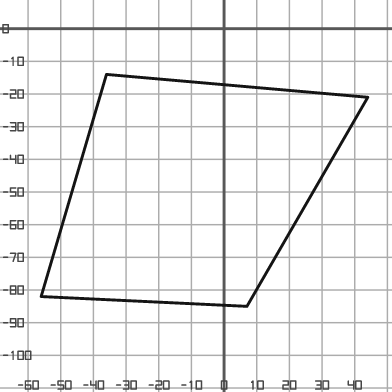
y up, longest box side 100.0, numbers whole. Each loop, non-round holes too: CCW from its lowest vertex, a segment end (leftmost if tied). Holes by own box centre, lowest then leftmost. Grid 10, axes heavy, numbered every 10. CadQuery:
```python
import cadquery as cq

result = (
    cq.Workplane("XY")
    .moveTo(7.0, -85.0)
    .lineTo(44.0, -21.0)
    .lineTo(-36.0, -14.0)
    .lineTo(-56.0, -82.0)
    .close()
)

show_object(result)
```